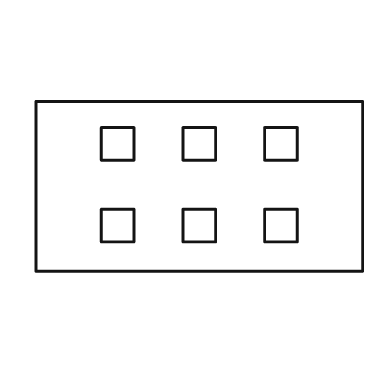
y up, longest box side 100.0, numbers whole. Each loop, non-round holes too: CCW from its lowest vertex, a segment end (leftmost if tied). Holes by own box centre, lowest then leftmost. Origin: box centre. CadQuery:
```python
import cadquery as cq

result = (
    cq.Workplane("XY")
    .moveTo(-50.0, -26.0)
    .lineTo(50.0, -26.0)
    .lineTo(50.0, 26.0)
    .lineTo(-50.0, 26.0)
    .close()
    .moveTo(-30.0, -17.0)
    .lineTo(-20.0, -17.0)
    .lineTo(-20.0, -7.0)
    .lineTo(-30.0, -7.0)
    .close()
    .moveTo(-5.0, -17.0)
    .lineTo(5.0, -17.0)
    .lineTo(5.0, -7.0)
    .lineTo(-5.0, -7.0)
    .close()
    .moveTo(20.0, -17.0)
    .lineTo(30.0, -17.0)
    .lineTo(30.0, -7.0)
    .lineTo(20.0, -7.0)
    .close()
    .moveTo(-30.0, 8.0)
    .lineTo(-20.0, 8.0)
    .lineTo(-20.0, 18.0)
    .lineTo(-30.0, 18.0)
    .close()
    .moveTo(-5.0, 8.0)
    .lineTo(5.0, 8.0)
    .lineTo(5.0, 18.0)
    .lineTo(-5.0, 18.0)
    .close()
    .moveTo(20.0, 8.0)
    .lineTo(30.0, 8.0)
    .lineTo(30.0, 18.0)
    .lineTo(20.0, 18.0)
    .close()
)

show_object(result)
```